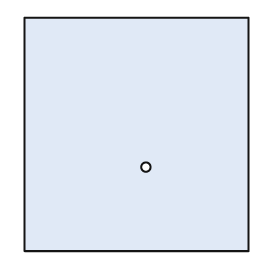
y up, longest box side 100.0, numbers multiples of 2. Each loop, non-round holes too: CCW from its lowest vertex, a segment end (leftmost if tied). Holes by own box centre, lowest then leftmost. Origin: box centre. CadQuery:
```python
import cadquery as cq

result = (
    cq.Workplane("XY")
    .moveTo(-48.0, -50.0)
    .lineTo(48.0, -50.0)
    .lineTo(48.0, 50.0)
    .lineTo(-48.0, 50.0)
    .close()
    .moveTo(4.0, -14.0)
    .circle(2.0)
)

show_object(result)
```